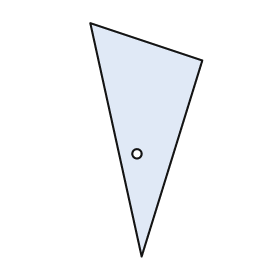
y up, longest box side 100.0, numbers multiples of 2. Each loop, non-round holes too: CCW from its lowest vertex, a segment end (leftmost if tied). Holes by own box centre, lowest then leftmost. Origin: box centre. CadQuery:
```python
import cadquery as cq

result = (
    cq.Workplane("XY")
    .moveTo(-2.0, -50.0)
    .lineTo(24.0, 34.0)
    .lineTo(-24.0, 50.0)
    .close()
    .moveTo(-4.0, -6.0)
    .circle(2.0)
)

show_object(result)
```